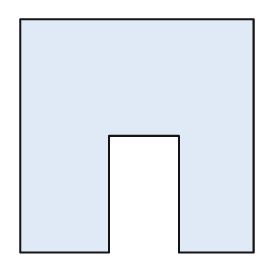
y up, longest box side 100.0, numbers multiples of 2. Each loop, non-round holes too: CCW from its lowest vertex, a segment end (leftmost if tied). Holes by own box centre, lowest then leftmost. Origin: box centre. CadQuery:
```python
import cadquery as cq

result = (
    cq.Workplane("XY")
    .moveTo(-50.0, -50.0)
    .lineTo(-12.0, -50.0)
    .lineTo(-12.0, 0.0)
    .lineTo(18.0, 0.0)
    .lineTo(18.0, -50.0)
    .lineTo(50.0, -50.0)
    .lineTo(50.0, 50.0)
    .lineTo(-50.0, 50.0)
    .close()
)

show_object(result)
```